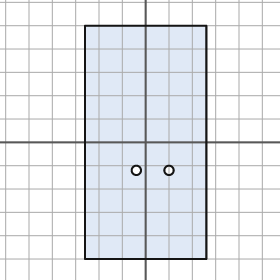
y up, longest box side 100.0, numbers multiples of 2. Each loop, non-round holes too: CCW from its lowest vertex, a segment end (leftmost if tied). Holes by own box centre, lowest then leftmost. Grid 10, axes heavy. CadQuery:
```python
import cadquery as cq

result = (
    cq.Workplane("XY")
    .moveTo(-26.0, -50.0)
    .lineTo(26.0, -50.0)
    .lineTo(26.0, 50.0)
    .lineTo(-26.0, 50.0)
    .close()
    .moveTo(-4.0, -12.0)
    .circle(2.0)
    .moveTo(10.0, -12.0)
    .circle(2.0)
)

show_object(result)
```